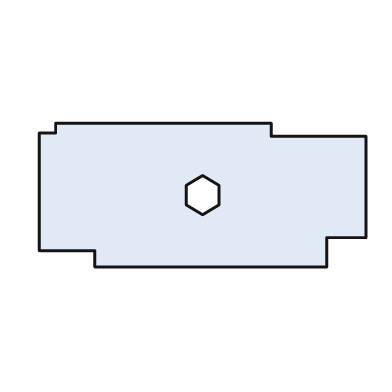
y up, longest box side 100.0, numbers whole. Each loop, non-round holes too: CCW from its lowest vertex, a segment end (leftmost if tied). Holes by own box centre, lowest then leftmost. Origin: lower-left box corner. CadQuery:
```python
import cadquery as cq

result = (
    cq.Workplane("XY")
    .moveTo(17.0, 0.0)
    .lineTo(88.0, 0.0)
    .lineTo(88.0, 9.0)
    .lineTo(100.0, 9.0)
    .lineTo(100.0, 40.0)
    .lineTo(71.0, 40.0)
    .lineTo(71.0, 44.0)
    .lineTo(5.0, 44.0)
    .lineTo(5.0, 41.0)
    .lineTo(0.0, 41.0)
    .lineTo(0.0, 5.0)
    .lineTo(17.0, 5.0)
    .close()
    .moveTo(50.0, 16.0)
    .lineTo(55.0, 19.0)
    .lineTo(55.0, 25.0)
    .lineTo(50.0, 28.0)
    .lineTo(45.0, 25.0)
    .lineTo(45.0, 19.0)
    .close()
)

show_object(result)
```